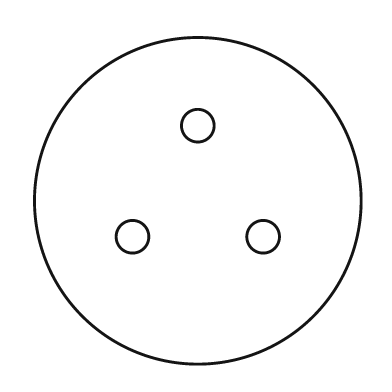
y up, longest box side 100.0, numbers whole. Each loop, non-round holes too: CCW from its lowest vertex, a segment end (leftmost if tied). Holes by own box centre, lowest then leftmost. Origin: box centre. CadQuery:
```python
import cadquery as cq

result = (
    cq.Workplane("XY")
    .moveTo(0.0, 0.0)
    .circle(50.0)
    .moveTo(-20.0, -11.0)
    .circle(5.0)
    .moveTo(20.0, -11.0)
    .circle(5.0)
    .moveTo(0.0, 23.0)
    .circle(5.0)
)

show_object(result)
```